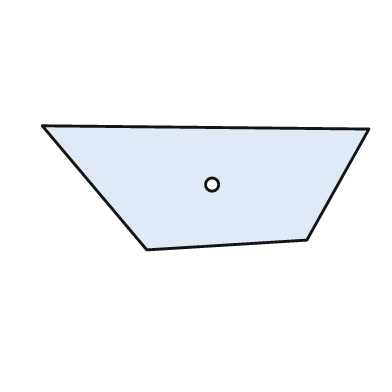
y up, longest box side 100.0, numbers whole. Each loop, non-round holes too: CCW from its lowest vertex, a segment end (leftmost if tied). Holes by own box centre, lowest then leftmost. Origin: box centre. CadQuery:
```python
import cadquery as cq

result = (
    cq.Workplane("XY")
    .moveTo(-18.0, -19.0)
    .lineTo(31.0, -16.0)
    .lineTo(50.0, 18.0)
    .lineTo(-50.0, 19.0)
    .close()
    .moveTo(2.0, 1.0)
    .circle(2.0)
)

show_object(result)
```